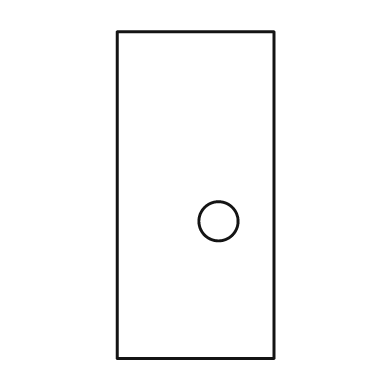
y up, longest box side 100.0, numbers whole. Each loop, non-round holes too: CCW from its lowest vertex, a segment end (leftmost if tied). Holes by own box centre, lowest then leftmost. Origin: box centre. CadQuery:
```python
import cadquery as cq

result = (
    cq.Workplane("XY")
    .moveTo(-24.0, -50.0)
    .lineTo(24.0, -50.0)
    .lineTo(24.0, 50.0)
    .lineTo(-24.0, 50.0)
    .close()
    .moveTo(7.0, -8.0)
    .circle(6.0)
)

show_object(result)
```